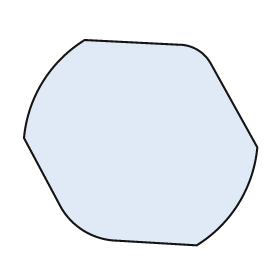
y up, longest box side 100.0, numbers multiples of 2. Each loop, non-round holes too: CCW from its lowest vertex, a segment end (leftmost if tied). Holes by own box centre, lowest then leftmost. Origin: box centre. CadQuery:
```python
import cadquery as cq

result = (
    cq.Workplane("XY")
    .moveTo(24.0, -44.0)
    .threePointArc((42.0, -26.0), (50.0, -2.0))
    .lineTo(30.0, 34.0)
    .threePointArc((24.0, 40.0), (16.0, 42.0))
    .lineTo(-24.0, 44.0)
    .threePointArc((-42.0, 26.0), (-50.0, 2.0))
    .lineTo(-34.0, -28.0)
    .threePointArc((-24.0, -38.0), (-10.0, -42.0))
    .close()
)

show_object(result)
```